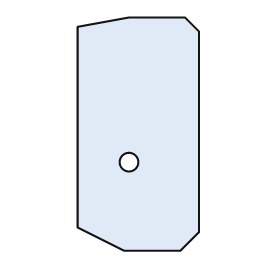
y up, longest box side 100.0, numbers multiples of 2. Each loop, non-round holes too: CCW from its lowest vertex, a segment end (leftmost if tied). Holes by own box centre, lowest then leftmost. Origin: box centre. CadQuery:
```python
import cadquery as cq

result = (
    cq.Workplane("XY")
    .moveTo(-6.0, -50.0)
    .lineTo(18.0, -50.0)
    .lineTo(26.0, -42.0)
    .lineTo(26.0, 44.0)
    .lineTo(20.0, 50.0)
    .lineTo(-4.0, 50.0)
    .lineTo(-26.0, 46.0)
    .lineTo(-26.0, -40.0)
    .close()
    .moveTo(-4.0, -12.0)
    .circle(4.0)
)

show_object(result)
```